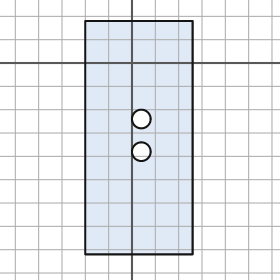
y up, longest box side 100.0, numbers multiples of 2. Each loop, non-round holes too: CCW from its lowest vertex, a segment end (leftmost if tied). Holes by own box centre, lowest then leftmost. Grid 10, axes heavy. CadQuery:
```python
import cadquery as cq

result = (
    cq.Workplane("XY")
    .moveTo(-20.0, -82.0)
    .lineTo(26.0, -82.0)
    .lineTo(26.0, 18.0)
    .lineTo(-20.0, 18.0)
    .close()
    .moveTo(4.0, -38.0)
    .circle(4.0)
    .moveTo(4.0, -24.0)
    .circle(4.0)
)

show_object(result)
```